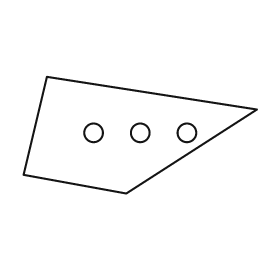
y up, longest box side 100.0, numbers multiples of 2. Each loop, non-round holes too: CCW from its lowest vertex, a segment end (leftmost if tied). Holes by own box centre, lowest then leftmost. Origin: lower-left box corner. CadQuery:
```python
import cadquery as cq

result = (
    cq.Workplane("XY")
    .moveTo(44.0, 0.0)
    .lineTo(100.0, 36.0)
    .lineTo(10.0, 50.0)
    .lineTo(0.0, 8.0)
    .close()
    .moveTo(30.0, 26.0)
    .circle(4.0)
    .moveTo(50.0, 26.0)
    .circle(4.0)
    .moveTo(70.0, 26.0)
    .circle(4.0)
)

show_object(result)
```